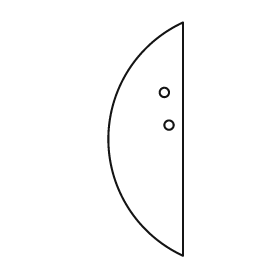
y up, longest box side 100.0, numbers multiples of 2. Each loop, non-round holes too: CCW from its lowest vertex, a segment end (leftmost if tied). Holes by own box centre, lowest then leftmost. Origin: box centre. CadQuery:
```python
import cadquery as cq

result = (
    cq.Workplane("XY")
    .moveTo(16.0, -50.0)
    .lineTo(16.0, 50.0)
    .threePointArc((-16.0, 0.0), (16.0, -50.0))
    .close()
    .moveTo(10.0, 6.0)
    .circle(2.0)
    .moveTo(8.0, 20.0)
    .circle(2.0)
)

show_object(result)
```